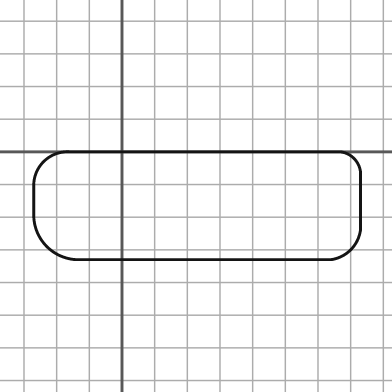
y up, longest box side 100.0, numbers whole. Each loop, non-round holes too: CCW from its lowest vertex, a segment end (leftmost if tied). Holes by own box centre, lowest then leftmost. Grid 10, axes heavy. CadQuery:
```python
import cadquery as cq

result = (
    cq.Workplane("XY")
    .moveTo(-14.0, -33.0)
    .lineTo(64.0, -33.0)
    .threePointArc((70.0, -30.0), (73.0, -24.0))
    .lineTo(73.0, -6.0)
    .threePointArc((71.0, -2.0), (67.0, 0.0))
    .lineTo(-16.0, 0.0)
    .threePointArc((-24.0, -3.0), (-27.0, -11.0))
    .lineTo(-27.0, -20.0)
    .threePointArc((-23.0, -29.0), (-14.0, -33.0))
    .close()
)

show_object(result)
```